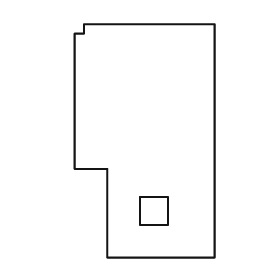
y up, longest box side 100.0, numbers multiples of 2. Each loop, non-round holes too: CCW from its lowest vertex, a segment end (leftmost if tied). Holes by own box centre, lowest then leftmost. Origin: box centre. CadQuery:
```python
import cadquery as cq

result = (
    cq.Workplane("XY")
    .moveTo(-16.0, -50.0)
    .lineTo(30.0, -50.0)
    .lineTo(30.0, 50.0)
    .lineTo(-26.0, 50.0)
    .lineTo(-26.0, 46.0)
    .lineTo(-30.0, 46.0)
    .lineTo(-30.0, -12.0)
    .lineTo(-16.0, -12.0)
    .close()
    .moveTo(-2.0, -36.0)
    .lineTo(10.0, -36.0)
    .lineTo(10.0, -24.0)
    .lineTo(-2.0, -24.0)
    .close()
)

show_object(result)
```